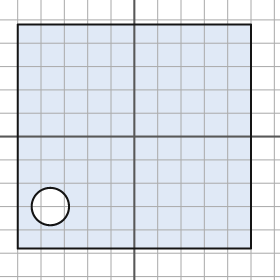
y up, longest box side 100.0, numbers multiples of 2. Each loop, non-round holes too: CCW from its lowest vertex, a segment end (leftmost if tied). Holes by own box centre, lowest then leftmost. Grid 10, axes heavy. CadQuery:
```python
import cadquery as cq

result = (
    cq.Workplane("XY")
    .moveTo(-50.0, -48.0)
    .lineTo(50.0, -48.0)
    .lineTo(50.0, 48.0)
    .lineTo(-50.0, 48.0)
    .close()
    .moveTo(-36.0, -30.0)
    .circle(8.0)
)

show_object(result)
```